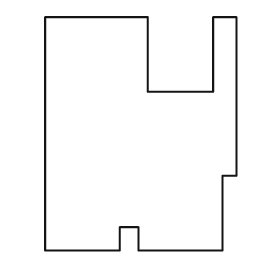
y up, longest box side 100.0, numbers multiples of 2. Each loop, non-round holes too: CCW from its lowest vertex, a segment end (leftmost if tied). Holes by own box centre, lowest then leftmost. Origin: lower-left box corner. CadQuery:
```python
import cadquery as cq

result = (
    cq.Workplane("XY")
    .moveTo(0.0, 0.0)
    .lineTo(32.0, 0.0)
    .lineTo(32.0, 10.0)
    .lineTo(40.0, 10.0)
    .lineTo(40.0, 0.0)
    .lineTo(76.0, 0.0)
    .lineTo(76.0, 32.0)
    .lineTo(82.0, 32.0)
    .lineTo(82.0, 100.0)
    .lineTo(72.0, 100.0)
    .lineTo(72.0, 68.0)
    .lineTo(44.0, 68.0)
    .lineTo(44.0, 100.0)
    .lineTo(0.0, 100.0)
    .close()
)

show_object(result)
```